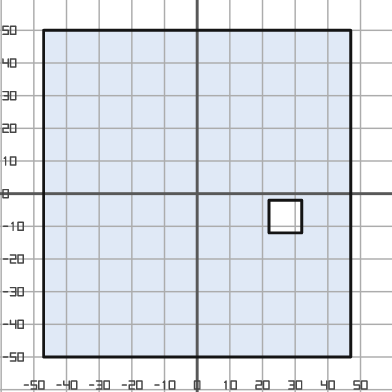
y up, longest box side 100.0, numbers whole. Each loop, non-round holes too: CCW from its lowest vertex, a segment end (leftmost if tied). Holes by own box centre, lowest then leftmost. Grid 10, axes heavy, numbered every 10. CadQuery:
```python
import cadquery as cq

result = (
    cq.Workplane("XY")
    .moveTo(-47.0, -50.0)
    .lineTo(47.0, -50.0)
    .lineTo(47.0, 50.0)
    .lineTo(-47.0, 50.0)
    .close()
    .moveTo(22.0, -12.0)
    .lineTo(32.0, -12.0)
    .lineTo(32.0, -2.0)
    .lineTo(22.0, -2.0)
    .close()
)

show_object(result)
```